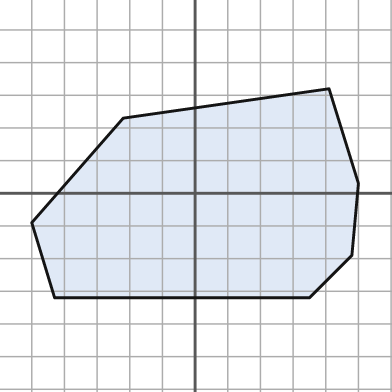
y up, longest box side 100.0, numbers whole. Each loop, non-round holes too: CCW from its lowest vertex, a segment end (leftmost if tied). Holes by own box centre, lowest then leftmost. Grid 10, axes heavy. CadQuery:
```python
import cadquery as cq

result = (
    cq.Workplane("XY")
    .moveTo(-43.0, -32.0)
    .lineTo(35.0, -32.0)
    .lineTo(48.0, -19.0)
    .lineTo(50.0, 3.0)
    .lineTo(41.0, 32.0)
    .lineTo(-22.0, 23.0)
    .lineTo(-50.0, -9.0)
    .close()
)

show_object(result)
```